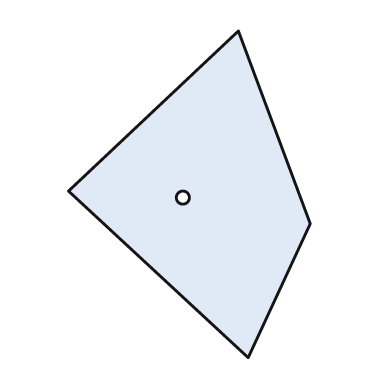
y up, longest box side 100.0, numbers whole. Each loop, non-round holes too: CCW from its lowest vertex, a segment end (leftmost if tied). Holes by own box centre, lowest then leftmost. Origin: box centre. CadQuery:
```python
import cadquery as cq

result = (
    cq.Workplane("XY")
    .moveTo(18.0, -50.0)
    .lineTo(37.0, -9.0)
    .lineTo(15.0, 50.0)
    .lineTo(-37.0, 1.0)
    .close()
    .moveTo(-2.0, -1.0)
    .circle(2.0)
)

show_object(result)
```